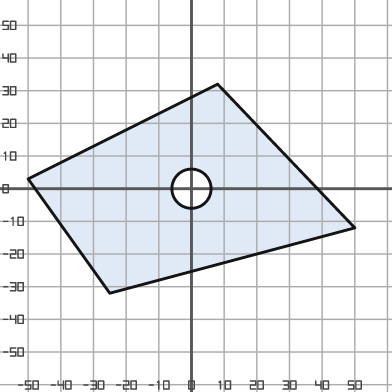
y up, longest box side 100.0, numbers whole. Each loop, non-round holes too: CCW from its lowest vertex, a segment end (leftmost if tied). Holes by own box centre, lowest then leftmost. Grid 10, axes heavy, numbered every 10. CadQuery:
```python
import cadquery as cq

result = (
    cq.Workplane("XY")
    .moveTo(-25.0, -32.0)
    .lineTo(50.0, -12.0)
    .lineTo(8.0, 32.0)
    .lineTo(-50.0, 3.0)
    .close()
    .moveTo(0.0, 0.0)
    .circle(6.0)
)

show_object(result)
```